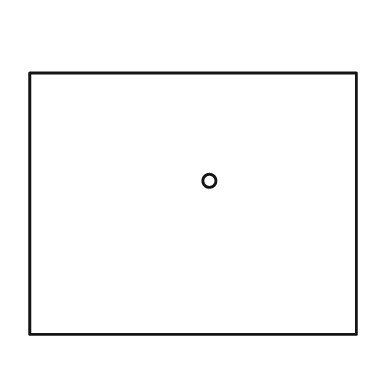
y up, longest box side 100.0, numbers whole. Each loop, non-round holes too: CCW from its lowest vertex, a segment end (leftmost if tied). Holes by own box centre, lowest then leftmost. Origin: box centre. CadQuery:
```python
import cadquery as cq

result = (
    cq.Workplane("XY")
    .moveTo(-50.0, -40.0)
    .lineTo(50.0, -40.0)
    .lineTo(50.0, 40.0)
    .lineTo(-50.0, 40.0)
    .close()
    .moveTo(5.0, 7.0)
    .circle(2.0)
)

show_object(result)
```